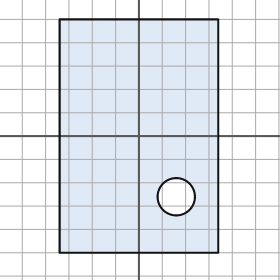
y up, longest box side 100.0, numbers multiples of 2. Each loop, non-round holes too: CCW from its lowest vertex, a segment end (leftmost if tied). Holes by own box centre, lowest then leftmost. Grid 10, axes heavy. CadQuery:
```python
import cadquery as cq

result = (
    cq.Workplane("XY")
    .moveTo(-34.0, -50.0)
    .lineTo(34.0, -50.0)
    .lineTo(34.0, 50.0)
    .lineTo(-34.0, 50.0)
    .close()
    .moveTo(16.0, -26.0)
    .circle(8.0)
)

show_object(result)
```